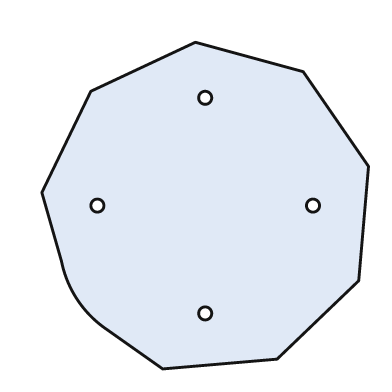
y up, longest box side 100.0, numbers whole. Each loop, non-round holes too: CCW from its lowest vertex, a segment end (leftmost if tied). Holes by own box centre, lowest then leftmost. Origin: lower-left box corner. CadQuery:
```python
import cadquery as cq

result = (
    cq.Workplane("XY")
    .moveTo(37.0, 0.0)
    .lineTo(72.0, 3.0)
    .lineTo(97.0, 27.0)
    .lineTo(100.0, 62.0)
    .lineTo(80.0, 91.0)
    .lineTo(47.0, 100.0)
    .lineTo(15.0, 85.0)
    .lineTo(0.0, 54.0)
    .lineTo(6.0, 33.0)
    .threePointArc((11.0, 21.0), (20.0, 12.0))
    .close()
    .moveTo(50.0, 17.0)
    .circle(2.0)
    .moveTo(17.0, 50.0)
    .circle(2.0)
    .moveTo(83.0, 50.0)
    .circle(2.0)
    .moveTo(50.0, 83.0)
    .circle(2.0)
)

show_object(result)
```